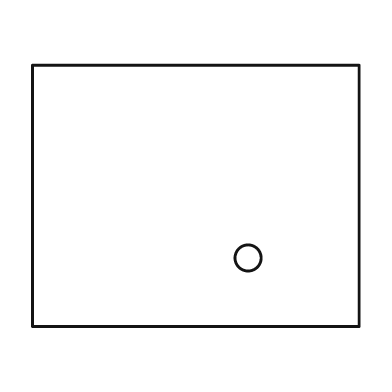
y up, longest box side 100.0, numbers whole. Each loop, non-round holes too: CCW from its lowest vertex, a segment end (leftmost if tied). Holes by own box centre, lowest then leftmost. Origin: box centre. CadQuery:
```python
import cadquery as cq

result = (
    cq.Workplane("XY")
    .moveTo(-50.0, -40.0)
    .lineTo(50.0, -40.0)
    .lineTo(50.0, 40.0)
    .lineTo(-50.0, 40.0)
    .close()
    .moveTo(16.0, -19.0)
    .circle(4.0)
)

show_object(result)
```